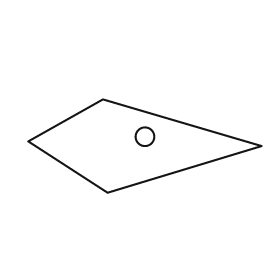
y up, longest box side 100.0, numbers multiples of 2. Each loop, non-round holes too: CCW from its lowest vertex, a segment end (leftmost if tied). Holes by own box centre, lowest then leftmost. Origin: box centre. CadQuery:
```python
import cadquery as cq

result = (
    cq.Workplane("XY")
    .moveTo(-16.0, -20.0)
    .lineTo(50.0, 0.0)
    .lineTo(-18.0, 20.0)
    .lineTo(-50.0, 2.0)
    .close()
    .moveTo(0.0, 4.0)
    .circle(4.0)
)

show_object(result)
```